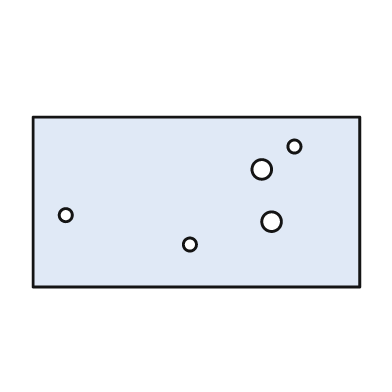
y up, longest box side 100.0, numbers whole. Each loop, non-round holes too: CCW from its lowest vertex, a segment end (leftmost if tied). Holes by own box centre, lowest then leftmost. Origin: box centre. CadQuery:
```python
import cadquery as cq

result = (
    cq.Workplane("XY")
    .moveTo(-50.0, -26.0)
    .lineTo(50.0, -26.0)
    .lineTo(50.0, 26.0)
    .lineTo(-50.0, 26.0)
    .close()
    .moveTo(-2.0, -13.0)
    .circle(2.0)
    .moveTo(23.0, -6.0)
    .circle(3.0)
    .moveTo(-40.0, -4.0)
    .circle(2.0)
    .moveTo(20.0, 10.0)
    .circle(3.0)
    .moveTo(30.0, 17.0)
    .circle(2.0)
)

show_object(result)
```